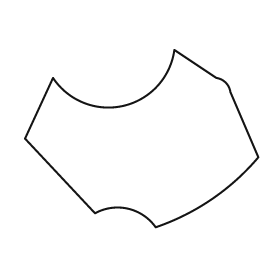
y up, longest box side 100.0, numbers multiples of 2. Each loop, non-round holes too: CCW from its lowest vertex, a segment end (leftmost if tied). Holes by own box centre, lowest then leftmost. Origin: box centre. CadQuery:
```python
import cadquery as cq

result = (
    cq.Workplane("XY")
    .moveTo(6.0, -38.0)
    .threePointArc((30.0, -26.0), (50.0, -8.0))
    .lineTo(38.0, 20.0)
    .threePointArc((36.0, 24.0), (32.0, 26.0))
    .lineTo(14.0, 38.0)
    .threePointArc((-8.0, 14.0), (-38.0, 26.0))
    .lineTo(-50.0, 0.0)
    .lineTo(-20.0, -32.0)
    .threePointArc((-6.0, -30.0), (6.0, -38.0))
    .close()
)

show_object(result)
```